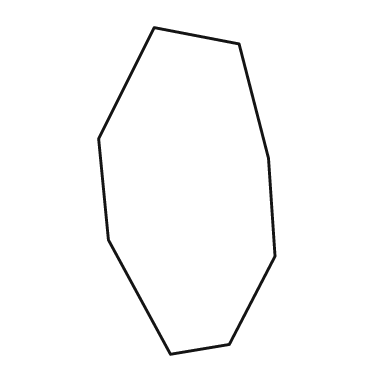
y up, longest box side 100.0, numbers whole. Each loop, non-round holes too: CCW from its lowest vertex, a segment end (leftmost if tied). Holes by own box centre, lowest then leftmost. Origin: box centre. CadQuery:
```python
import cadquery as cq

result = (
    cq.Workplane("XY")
    .moveTo(-5.0, -50.0)
    .lineTo(13.0, -47.0)
    .lineTo(27.0, -20.0)
    .lineTo(25.0, 10.0)
    .lineTo(16.0, 45.0)
    .lineTo(-10.0, 50.0)
    .lineTo(-27.0, 16.0)
    .lineTo(-24.0, -15.0)
    .close()
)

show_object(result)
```